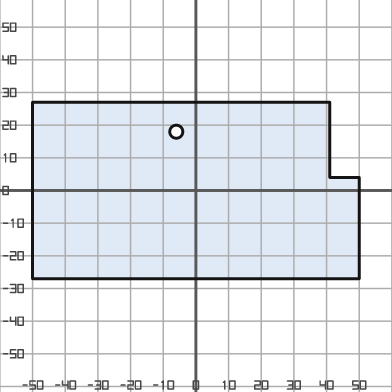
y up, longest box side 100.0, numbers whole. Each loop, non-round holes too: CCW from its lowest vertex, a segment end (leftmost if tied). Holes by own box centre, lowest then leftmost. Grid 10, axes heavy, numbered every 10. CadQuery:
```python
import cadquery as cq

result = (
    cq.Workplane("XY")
    .moveTo(-50.0, -27.0)
    .lineTo(50.0, -27.0)
    .lineTo(50.0, 4.0)
    .lineTo(41.0, 4.0)
    .lineTo(41.0, 27.0)
    .lineTo(-50.0, 27.0)
    .close()
    .moveTo(-6.0, 18.0)
    .circle(2.0)
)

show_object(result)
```